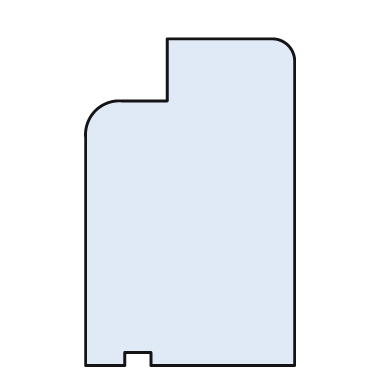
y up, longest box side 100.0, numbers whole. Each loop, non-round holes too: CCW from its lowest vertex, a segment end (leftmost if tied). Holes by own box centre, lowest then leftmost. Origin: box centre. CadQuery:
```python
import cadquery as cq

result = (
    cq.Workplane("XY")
    .moveTo(-32.0, -50.0)
    .lineTo(-20.0, -50.0)
    .lineTo(-20.0, -46.0)
    .lineTo(-12.0, -46.0)
    .lineTo(-12.0, -50.0)
    .lineTo(32.0, -50.0)
    .lineTo(32.0, 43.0)
    .threePointArc((30.0, 48.0), (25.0, 50.0))
    .lineTo(-7.0, 50.0)
    .lineTo(-7.0, 31.0)
    .lineTo(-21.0, 31.0)
    .threePointArc((-29.0, 28.0), (-32.0, 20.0))
    .close()
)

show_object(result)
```